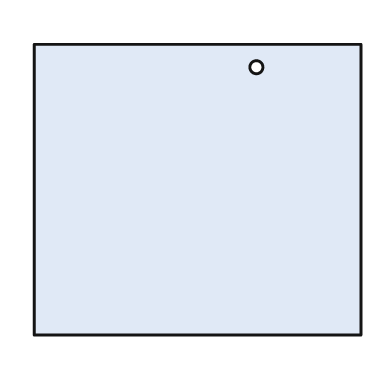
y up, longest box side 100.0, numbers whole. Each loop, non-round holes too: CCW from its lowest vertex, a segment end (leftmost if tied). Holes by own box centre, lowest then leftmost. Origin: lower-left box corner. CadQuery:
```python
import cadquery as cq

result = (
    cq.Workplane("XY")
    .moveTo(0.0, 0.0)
    .lineTo(100.0, 0.0)
    .lineTo(100.0, 89.0)
    .lineTo(0.0, 89.0)
    .close()
    .moveTo(68.0, 82.0)
    .circle(2.0)
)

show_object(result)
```